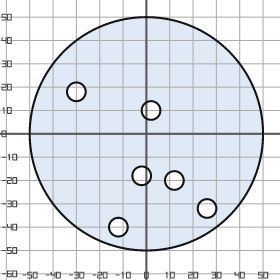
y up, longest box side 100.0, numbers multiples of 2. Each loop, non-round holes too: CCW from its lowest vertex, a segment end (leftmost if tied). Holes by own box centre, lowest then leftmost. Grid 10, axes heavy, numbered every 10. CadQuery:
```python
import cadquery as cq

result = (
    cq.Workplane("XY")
    .moveTo(0.0, 0.0)
    .circle(50.0)
    .moveTo(-12.0, -40.0)
    .circle(4.0)
    .moveTo(26.0, -32.0)
    .circle(4.0)
    .moveTo(12.0, -20.0)
    .circle(4.0)
    .moveTo(-2.0, -18.0)
    .circle(4.0)
    .moveTo(2.0, 10.0)
    .circle(4.0)
    .moveTo(-30.0, 18.0)
    .circle(4.0)
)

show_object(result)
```